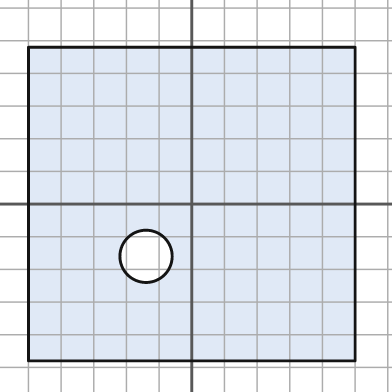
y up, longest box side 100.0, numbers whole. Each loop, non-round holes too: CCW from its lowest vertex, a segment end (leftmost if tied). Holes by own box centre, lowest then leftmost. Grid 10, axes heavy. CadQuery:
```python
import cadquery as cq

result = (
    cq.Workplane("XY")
    .moveTo(-50.0, -48.0)
    .lineTo(50.0, -48.0)
    .lineTo(50.0, 48.0)
    .lineTo(-50.0, 48.0)
    .close()
    .moveTo(-14.0, -16.0)
    .circle(8.0)
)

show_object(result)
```